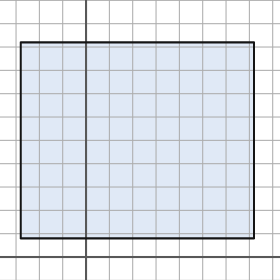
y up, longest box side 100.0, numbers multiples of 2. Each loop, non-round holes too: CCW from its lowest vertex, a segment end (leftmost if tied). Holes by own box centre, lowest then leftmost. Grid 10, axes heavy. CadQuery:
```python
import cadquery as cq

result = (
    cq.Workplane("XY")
    .moveTo(-28.0, 8.0)
    .lineTo(72.0, 8.0)
    .lineTo(72.0, 92.0)
    .lineTo(-28.0, 92.0)
    .close()
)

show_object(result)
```